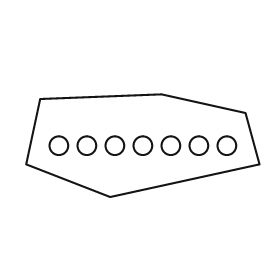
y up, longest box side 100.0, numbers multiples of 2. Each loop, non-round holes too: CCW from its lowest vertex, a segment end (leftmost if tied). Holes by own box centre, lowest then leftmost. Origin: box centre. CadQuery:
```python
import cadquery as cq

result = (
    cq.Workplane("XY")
    .moveTo(-14.0, -22.0)
    .lineTo(50.0, -8.0)
    .lineTo(44.0, 14.0)
    .lineTo(8.0, 22.0)
    .lineTo(-44.0, 20.0)
    .lineTo(-50.0, -8.0)
    .close()
    .moveTo(-36.0, 0.0)
    .circle(4.0)
    .moveTo(-24.0, 0.0)
    .circle(4.0)
    .moveTo(-12.0, 0.0)
    .circle(4.0)
    .moveTo(0.0, 0.0)
    .circle(4.0)
    .moveTo(12.0, 0.0)
    .circle(4.0)
    .moveTo(24.0, 0.0)
    .circle(4.0)
    .moveTo(36.0, 0.0)
    .circle(4.0)
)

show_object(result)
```